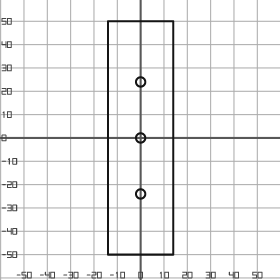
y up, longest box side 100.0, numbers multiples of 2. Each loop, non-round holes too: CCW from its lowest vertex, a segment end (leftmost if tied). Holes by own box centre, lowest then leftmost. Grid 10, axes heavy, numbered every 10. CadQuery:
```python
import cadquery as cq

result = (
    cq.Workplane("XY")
    .moveTo(-14.0, -50.0)
    .lineTo(14.0, -50.0)
    .lineTo(14.0, 50.0)
    .lineTo(-14.0, 50.0)
    .close()
    .moveTo(0.0, -24.0)
    .circle(2.0)
    .moveTo(0.0, 0.0)
    .circle(2.0)
    .moveTo(0.0, 24.0)
    .circle(2.0)
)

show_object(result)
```